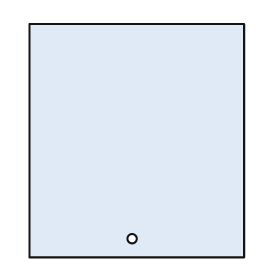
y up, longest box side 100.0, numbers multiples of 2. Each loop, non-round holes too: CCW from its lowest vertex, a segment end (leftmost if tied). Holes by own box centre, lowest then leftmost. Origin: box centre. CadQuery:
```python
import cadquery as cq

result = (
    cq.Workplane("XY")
    .moveTo(-46.0, -50.0)
    .lineTo(46.0, -50.0)
    .lineTo(46.0, 50.0)
    .lineTo(-46.0, 50.0)
    .close()
    .moveTo(-2.0, -42.0)
    .circle(2.0)
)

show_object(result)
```